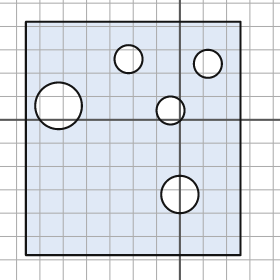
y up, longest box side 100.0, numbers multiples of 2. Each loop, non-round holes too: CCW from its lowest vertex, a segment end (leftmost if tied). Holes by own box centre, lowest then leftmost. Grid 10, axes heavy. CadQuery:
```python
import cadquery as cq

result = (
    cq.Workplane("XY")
    .moveTo(-66.0, -58.0)
    .lineTo(26.0, -58.0)
    .lineTo(26.0, 42.0)
    .lineTo(-66.0, 42.0)
    .close()
    .moveTo(0.0, -32.0)
    .circle(8.0)
    .moveTo(-4.0, 4.0)
    .circle(6.0)
    .moveTo(-52.0, 6.0)
    .circle(10.0)
    .moveTo(12.0, 24.0)
    .circle(6.0)
    .moveTo(-22.0, 26.0)
    .circle(6.0)
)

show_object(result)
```